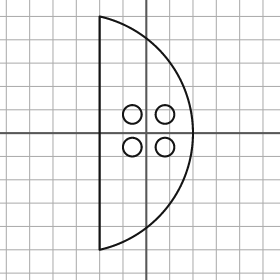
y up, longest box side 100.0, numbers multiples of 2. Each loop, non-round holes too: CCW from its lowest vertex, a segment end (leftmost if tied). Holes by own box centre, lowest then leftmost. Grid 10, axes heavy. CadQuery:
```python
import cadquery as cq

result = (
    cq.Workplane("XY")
    .moveTo(-20.0, -50.0)
    .threePointArc((20.0, 0.0), (-20.0, 50.0))
    .close()
    .moveTo(-6.0, -6.0)
    .circle(4.0)
    .moveTo(8.0, -6.0)
    .circle(4.0)
    .moveTo(-6.0, 8.0)
    .circle(4.0)
    .moveTo(8.0, 8.0)
    .circle(4.0)
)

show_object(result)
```